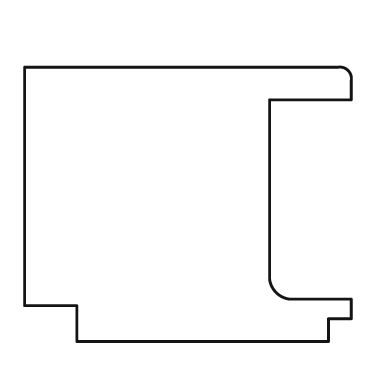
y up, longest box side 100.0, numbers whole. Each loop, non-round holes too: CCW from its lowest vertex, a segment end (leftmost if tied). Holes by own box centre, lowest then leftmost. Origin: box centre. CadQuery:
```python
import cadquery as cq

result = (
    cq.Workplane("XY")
    .moveTo(-34.0, -42.0)
    .lineTo(43.0, -42.0)
    .lineTo(43.0, -35.0)
    .lineTo(50.0, -35.0)
    .lineTo(50.0, -29.0)
    .lineTo(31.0, -29.0)
    .threePointArc((27.0, -27.0), (25.0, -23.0))
    .lineTo(25.0, 32.0)
    .lineTo(50.0, 32.0)
    .lineTo(50.0, 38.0)
    .threePointArc((49.0, 41.0), (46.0, 42.0))
    .lineTo(-50.0, 42.0)
    .lineTo(-50.0, -31.0)
    .lineTo(-34.0, -31.0)
    .close()
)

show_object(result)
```